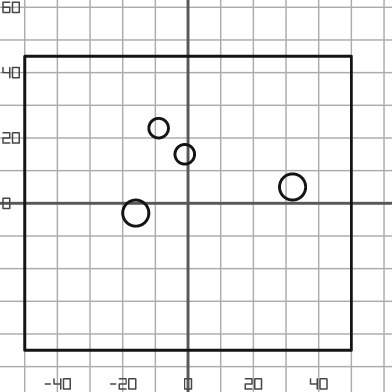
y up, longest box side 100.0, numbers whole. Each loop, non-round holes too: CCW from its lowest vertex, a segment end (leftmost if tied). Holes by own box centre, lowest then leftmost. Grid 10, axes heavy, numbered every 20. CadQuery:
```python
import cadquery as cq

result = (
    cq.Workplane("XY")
    .moveTo(-50.0, -45.0)
    .lineTo(50.0, -45.0)
    .lineTo(50.0, 45.0)
    .lineTo(-50.0, 45.0)
    .close()
    .moveTo(-16.0, -3.0)
    .circle(4.0)
    .moveTo(32.0, 5.0)
    .circle(4.0)
    .moveTo(-1.0, 15.0)
    .circle(3.0)
    .moveTo(-9.0, 23.0)
    .circle(3.0)
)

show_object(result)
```